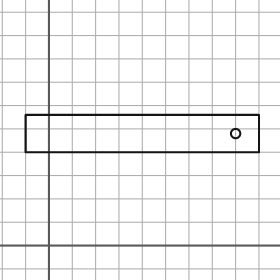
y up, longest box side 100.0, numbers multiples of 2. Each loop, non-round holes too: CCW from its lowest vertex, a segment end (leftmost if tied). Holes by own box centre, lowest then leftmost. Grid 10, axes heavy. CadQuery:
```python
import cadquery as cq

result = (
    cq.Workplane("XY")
    .moveTo(-10.0, 40.0)
    .lineTo(90.0, 40.0)
    .lineTo(90.0, 56.0)
    .lineTo(-10.0, 56.0)
    .close()
    .moveTo(80.0, 48.0)
    .circle(2.0)
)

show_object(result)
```